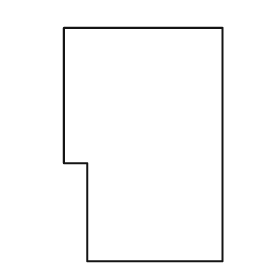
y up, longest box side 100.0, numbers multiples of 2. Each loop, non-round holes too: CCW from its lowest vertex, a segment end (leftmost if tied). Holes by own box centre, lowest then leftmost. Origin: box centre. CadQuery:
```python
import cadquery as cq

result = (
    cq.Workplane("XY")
    .moveTo(-24.0, -50.0)
    .lineTo(34.0, -50.0)
    .lineTo(34.0, 50.0)
    .lineTo(-34.0, 50.0)
    .lineTo(-34.0, -8.0)
    .lineTo(-24.0, -8.0)
    .close()
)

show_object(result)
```